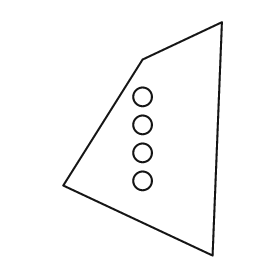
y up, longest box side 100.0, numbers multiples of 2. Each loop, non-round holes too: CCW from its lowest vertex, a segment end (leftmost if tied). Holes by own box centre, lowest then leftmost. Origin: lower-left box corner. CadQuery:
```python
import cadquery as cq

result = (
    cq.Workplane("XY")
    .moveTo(64.0, 0.0)
    .lineTo(68.0, 100.0)
    .lineTo(34.0, 84.0)
    .lineTo(0.0, 30.0)
    .close()
    .moveTo(34.0, 32.0)
    .circle(4.0)
    .moveTo(34.0, 44.0)
    .circle(4.0)
    .moveTo(34.0, 56.0)
    .circle(4.0)
    .moveTo(34.0, 68.0)
    .circle(4.0)
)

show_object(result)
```